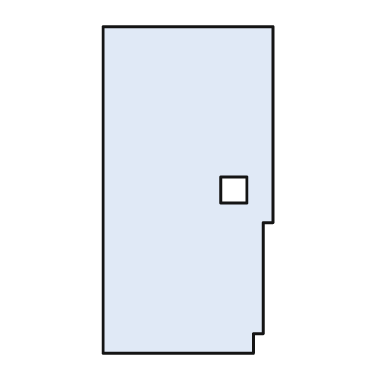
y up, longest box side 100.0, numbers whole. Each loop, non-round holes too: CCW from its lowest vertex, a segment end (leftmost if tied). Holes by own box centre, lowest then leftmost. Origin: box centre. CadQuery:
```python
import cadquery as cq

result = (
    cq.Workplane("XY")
    .moveTo(-26.0, -50.0)
    .lineTo(20.0, -50.0)
    .lineTo(20.0, -44.0)
    .lineTo(23.0, -44.0)
    .lineTo(23.0, -10.0)
    .lineTo(26.0, -10.0)
    .lineTo(26.0, 50.0)
    .lineTo(-26.0, 50.0)
    .close()
    .moveTo(10.0, -4.0)
    .lineTo(18.0, -4.0)
    .lineTo(18.0, 4.0)
    .lineTo(10.0, 4.0)
    .close()
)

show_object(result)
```